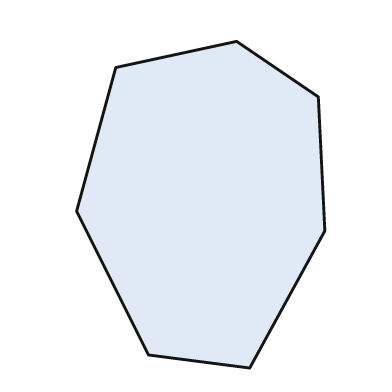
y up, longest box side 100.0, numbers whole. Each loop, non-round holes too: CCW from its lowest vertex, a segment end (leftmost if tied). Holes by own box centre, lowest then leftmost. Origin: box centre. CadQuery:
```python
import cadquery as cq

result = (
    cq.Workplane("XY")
    .moveTo(15.0, -50.0)
    .lineTo(38.0, -8.0)
    .lineTo(36.0, 33.0)
    .lineTo(11.0, 50.0)
    .lineTo(-26.0, 42.0)
    .lineTo(-38.0, -2.0)
    .lineTo(-16.0, -46.0)
    .close()
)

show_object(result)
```